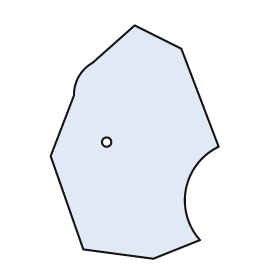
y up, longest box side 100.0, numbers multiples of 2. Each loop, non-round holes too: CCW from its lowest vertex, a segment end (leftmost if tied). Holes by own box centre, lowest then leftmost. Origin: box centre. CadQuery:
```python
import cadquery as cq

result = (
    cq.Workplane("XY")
    .moveTo(8.0, -50.0)
    .lineTo(28.0, -42.0)
    .threePointArc((22.0, -20.0), (36.0, -2.0))
    .lineTo(20.0, 40.0)
    .lineTo(0.0, 50.0)
    .lineTo(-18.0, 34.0)
    .threePointArc((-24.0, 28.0), (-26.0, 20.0))
    .lineTo(-36.0, -6.0)
    .lineTo(-22.0, -46.0)
    .close()
    .moveTo(-12.0, 0.0)
    .circle(2.0)
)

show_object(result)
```